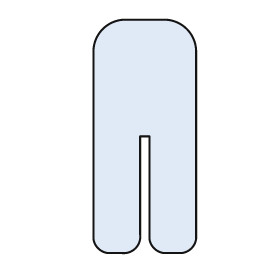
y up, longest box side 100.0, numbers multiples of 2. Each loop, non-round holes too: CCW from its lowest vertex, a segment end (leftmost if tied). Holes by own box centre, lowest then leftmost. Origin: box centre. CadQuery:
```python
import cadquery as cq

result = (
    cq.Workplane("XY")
    .moveTo(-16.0, -50.0)
    .lineTo(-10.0, -50.0)
    .threePointArc((-4.0, -48.0), (-2.0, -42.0))
    .lineTo(-2.0, 0.0)
    .lineTo(2.0, 0.0)
    .lineTo(2.0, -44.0)
    .threePointArc((4.0, -48.0), (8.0, -50.0))
    .lineTo(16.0, -50.0)
    .threePointArc((20.0, -48.0), (22.0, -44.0))
    .lineTo(22.0, 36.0)
    .threePointArc((18.0, 46.0), (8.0, 50.0))
    .lineTo(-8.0, 50.0)
    .threePointArc((-18.0, 46.0), (-22.0, 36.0))
    .lineTo(-22.0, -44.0)
    .threePointArc((-20.0, -48.0), (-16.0, -50.0))
    .close()
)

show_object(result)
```